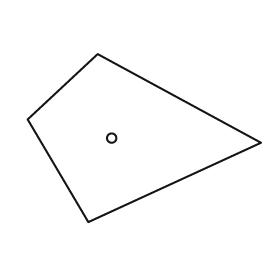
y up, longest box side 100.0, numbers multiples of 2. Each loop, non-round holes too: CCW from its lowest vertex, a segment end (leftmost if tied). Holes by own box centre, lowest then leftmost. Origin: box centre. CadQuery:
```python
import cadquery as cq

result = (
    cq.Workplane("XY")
    .moveTo(-24.0, -36.0)
    .lineTo(50.0, -2.0)
    .lineTo(-20.0, 36.0)
    .lineTo(-50.0, 8.0)
    .close()
    .moveTo(-14.0, 0.0)
    .circle(2.0)
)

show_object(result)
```